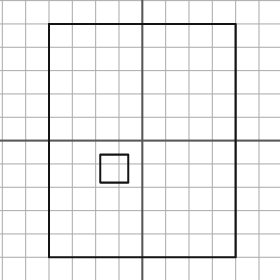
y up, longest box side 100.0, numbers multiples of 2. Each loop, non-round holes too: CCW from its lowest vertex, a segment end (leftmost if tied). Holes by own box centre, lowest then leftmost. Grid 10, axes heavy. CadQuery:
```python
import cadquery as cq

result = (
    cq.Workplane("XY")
    .moveTo(-40.0, -50.0)
    .lineTo(40.0, -50.0)
    .lineTo(40.0, 50.0)
    .lineTo(-40.0, 50.0)
    .close()
    .moveTo(-18.0, -18.0)
    .lineTo(-6.0, -18.0)
    .lineTo(-6.0, -6.0)
    .lineTo(-18.0, -6.0)
    .close()
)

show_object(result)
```